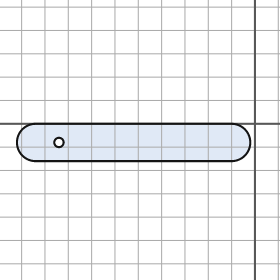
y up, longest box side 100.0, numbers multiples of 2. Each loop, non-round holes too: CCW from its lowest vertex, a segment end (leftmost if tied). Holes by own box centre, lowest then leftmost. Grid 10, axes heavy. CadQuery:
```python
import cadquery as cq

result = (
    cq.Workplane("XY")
    .moveTo(-94.0, -16.0)
    .lineTo(-10.0, -16.0)
    .threePointArc((-2.0, -8.0), (-10.0, 0.0))
    .lineTo(-94.0, 0.0)
    .threePointArc((-102.0, -8.0), (-94.0, -16.0))
    .close()
    .moveTo(-84.0, -8.0)
    .circle(2.0)
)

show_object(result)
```